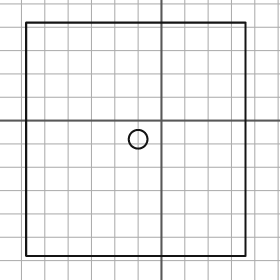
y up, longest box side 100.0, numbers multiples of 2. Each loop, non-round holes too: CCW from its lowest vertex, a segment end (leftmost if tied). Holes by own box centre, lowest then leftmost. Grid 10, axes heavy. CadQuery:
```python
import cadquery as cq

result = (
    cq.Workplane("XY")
    .moveTo(-58.0, -58.0)
    .lineTo(36.0, -58.0)
    .lineTo(36.0, 42.0)
    .lineTo(-58.0, 42.0)
    .close()
    .moveTo(-10.0, -8.0)
    .circle(4.0)
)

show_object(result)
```